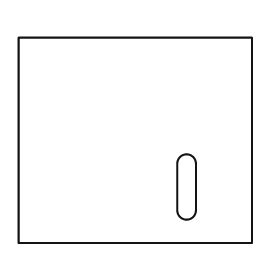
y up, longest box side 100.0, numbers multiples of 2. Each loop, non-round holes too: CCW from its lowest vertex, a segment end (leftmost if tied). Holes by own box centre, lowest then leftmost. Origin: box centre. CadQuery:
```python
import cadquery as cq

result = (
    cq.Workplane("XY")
    .moveTo(-50.0, -44.0)
    .lineTo(50.0, -44.0)
    .lineTo(50.0, 44.0)
    .lineTo(-50.0, 44.0)
    .close()
    .moveTo(18.0, -30.0)
    .threePointArc((22.0, -34.0), (26.0, -30.0))
    .lineTo(26.0, -10.0)
    .threePointArc((22.0, -6.0), (18.0, -10.0))
    .close()
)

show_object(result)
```